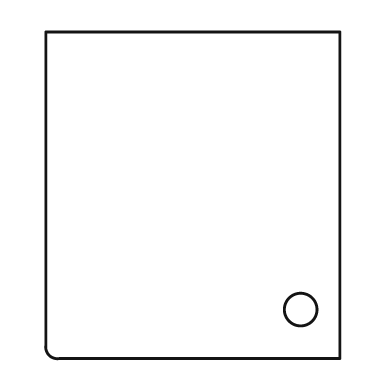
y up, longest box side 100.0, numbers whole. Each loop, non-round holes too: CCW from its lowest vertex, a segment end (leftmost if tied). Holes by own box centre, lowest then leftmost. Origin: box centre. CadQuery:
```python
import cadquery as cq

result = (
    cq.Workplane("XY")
    .moveTo(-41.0, -50.0)
    .lineTo(45.0, -50.0)
    .lineTo(45.0, 50.0)
    .lineTo(-45.0, 50.0)
    .lineTo(-45.0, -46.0)
    .threePointArc((-44.0, -49.0), (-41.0, -50.0))
    .close()
    .moveTo(33.0, -35.0)
    .circle(5.0)
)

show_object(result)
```